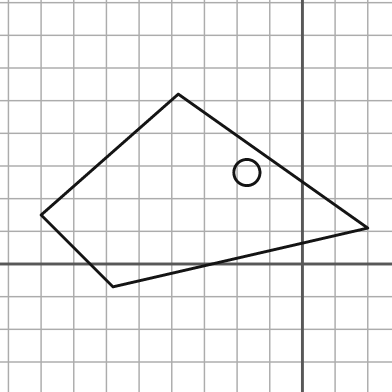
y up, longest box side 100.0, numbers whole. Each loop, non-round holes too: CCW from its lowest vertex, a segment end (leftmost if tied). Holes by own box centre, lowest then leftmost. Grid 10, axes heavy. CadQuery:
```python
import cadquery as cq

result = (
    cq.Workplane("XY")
    .moveTo(-58.0, -7.0)
    .lineTo(20.0, 11.0)
    .lineTo(-38.0, 52.0)
    .lineTo(-80.0, 15.0)
    .close()
    .moveTo(-17.0, 28.0)
    .circle(4.0)
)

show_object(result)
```